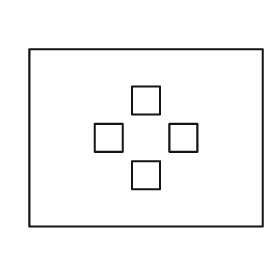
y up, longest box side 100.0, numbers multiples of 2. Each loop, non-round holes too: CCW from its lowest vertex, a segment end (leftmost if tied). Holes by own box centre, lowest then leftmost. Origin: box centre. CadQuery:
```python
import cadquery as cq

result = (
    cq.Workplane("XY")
    .moveTo(-50.0, -38.0)
    .lineTo(50.0, -38.0)
    .lineTo(50.0, 38.0)
    .lineTo(-50.0, 38.0)
    .close()
    .moveTo(-6.0, -22.0)
    .lineTo(6.0, -22.0)
    .lineTo(6.0, -10.0)
    .lineTo(-6.0, -10.0)
    .close()
    .moveTo(-22.0, -6.0)
    .lineTo(-10.0, -6.0)
    .lineTo(-10.0, 6.0)
    .lineTo(-22.0, 6.0)
    .close()
    .moveTo(10.0, -6.0)
    .lineTo(22.0, -6.0)
    .lineTo(22.0, 6.0)
    .lineTo(10.0, 6.0)
    .close()
    .moveTo(-6.0, 10.0)
    .lineTo(6.0, 10.0)
    .lineTo(6.0, 22.0)
    .lineTo(-6.0, 22.0)
    .close()
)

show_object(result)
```